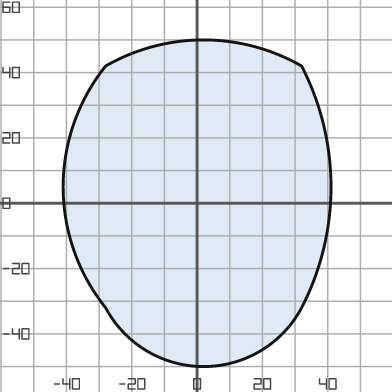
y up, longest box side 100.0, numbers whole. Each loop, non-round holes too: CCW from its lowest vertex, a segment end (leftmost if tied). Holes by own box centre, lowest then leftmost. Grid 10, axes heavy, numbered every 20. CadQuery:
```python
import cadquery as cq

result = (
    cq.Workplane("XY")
    .moveTo(-28.0, -32.0)
    .threePointArc((2.0, -50.0), (32.0, -32.0))
    .threePointArc((41.0, 5.0), (32.0, 42.0))
    .threePointArc((2.0, 50.0), (-28.0, 42.0))
    .threePointArc((-41.0, 5.0), (-28.0, -32.0))
    .close()
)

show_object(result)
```